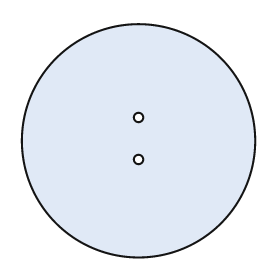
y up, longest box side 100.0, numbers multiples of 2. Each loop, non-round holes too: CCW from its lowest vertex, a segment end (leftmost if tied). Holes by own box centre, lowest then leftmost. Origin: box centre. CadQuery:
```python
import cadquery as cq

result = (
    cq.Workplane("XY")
    .moveTo(0.0, 0.0)
    .circle(50.0)
    .moveTo(0.0, -8.0)
    .circle(2.0)
    .moveTo(0.0, 10.0)
    .circle(2.0)
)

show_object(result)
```